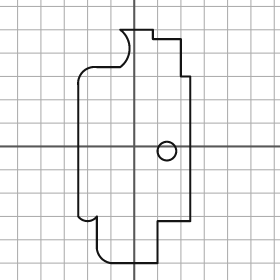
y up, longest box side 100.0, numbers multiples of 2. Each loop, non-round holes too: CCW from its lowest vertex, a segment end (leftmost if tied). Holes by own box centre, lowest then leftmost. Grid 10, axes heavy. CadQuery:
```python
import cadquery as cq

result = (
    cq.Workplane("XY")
    .moveTo(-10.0, -50.0)
    .lineTo(10.0, -50.0)
    .lineTo(10.0, -32.0)
    .lineTo(24.0, -32.0)
    .lineTo(24.0, 30.0)
    .lineTo(20.0, 30.0)
    .lineTo(20.0, 46.0)
    .lineTo(8.0, 46.0)
    .lineTo(8.0, 50.0)
    .lineTo(-6.0, 50.0)
    .threePointArc((-2.0, 42.0), (-6.0, 34.0))
    .lineTo(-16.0, 34.0)
    .threePointArc((-22.0, 32.0), (-24.0, 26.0))
    .lineTo(-24.0, -30.0)
    .threePointArc((-20.0, -32.0), (-16.0, -30.0))
    .lineTo(-16.0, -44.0)
    .threePointArc((-14.0, -48.0), (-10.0, -50.0))
    .close()
    .moveTo(14.0, -2.0)
    .circle(4.0)
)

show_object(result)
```